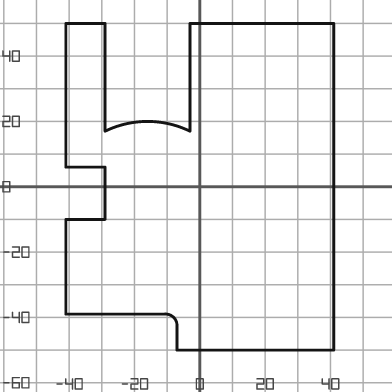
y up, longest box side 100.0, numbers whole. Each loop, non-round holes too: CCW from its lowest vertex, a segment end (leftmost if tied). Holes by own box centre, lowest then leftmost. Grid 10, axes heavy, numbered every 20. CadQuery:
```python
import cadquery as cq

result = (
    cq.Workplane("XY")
    .moveTo(-7.0, -50.0)
    .lineTo(41.0, -50.0)
    .lineTo(41.0, 50.0)
    .lineTo(-3.0, 50.0)
    .lineTo(-3.0, 17.0)
    .threePointArc((-16.0, 20.0), (-29.0, 17.0))
    .lineTo(-29.0, 50.0)
    .lineTo(-41.0, 50.0)
    .lineTo(-41.0, 6.0)
    .lineTo(-29.0, 6.0)
    .lineTo(-29.0, -10.0)
    .lineTo(-41.0, -10.0)
    .lineTo(-41.0, -39.0)
    .lineTo(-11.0, -39.0)
    .threePointArc((-8.0, -40.0), (-7.0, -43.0))
    .close()
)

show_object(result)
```